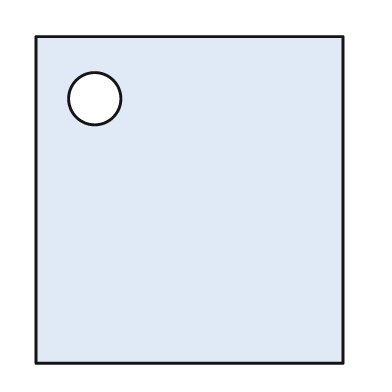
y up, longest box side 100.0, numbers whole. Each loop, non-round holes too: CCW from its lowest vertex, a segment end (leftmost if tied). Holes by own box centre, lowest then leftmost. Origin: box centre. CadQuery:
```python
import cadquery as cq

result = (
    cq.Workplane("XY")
    .moveTo(-47.0, -50.0)
    .lineTo(47.0, -50.0)
    .lineTo(47.0, 50.0)
    .lineTo(-47.0, 50.0)
    .close()
    .moveTo(-29.0, 31.0)
    .circle(8.0)
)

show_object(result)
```